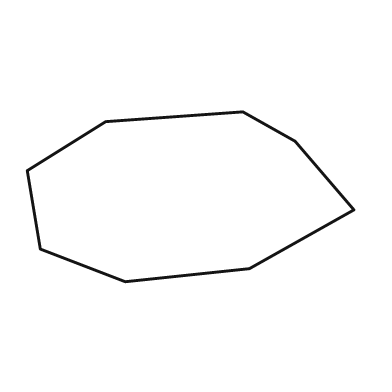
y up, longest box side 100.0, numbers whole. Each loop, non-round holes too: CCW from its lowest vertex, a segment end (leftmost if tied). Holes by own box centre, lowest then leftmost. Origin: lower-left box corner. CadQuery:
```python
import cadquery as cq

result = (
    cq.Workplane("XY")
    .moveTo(30.0, 0.0)
    .lineTo(68.0, 4.0)
    .lineTo(100.0, 22.0)
    .lineTo(82.0, 43.0)
    .lineTo(66.0, 52.0)
    .lineTo(24.0, 49.0)
    .lineTo(0.0, 34.0)
    .lineTo(4.0, 10.0)
    .close()
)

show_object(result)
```